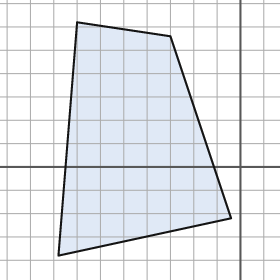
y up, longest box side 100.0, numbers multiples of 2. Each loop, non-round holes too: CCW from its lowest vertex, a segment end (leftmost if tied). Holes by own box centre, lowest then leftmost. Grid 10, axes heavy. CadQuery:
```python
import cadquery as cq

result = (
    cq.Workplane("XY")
    .moveTo(-78.0, -38.0)
    .lineTo(-4.0, -22.0)
    .lineTo(-30.0, 56.0)
    .lineTo(-70.0, 62.0)
    .close()
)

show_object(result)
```